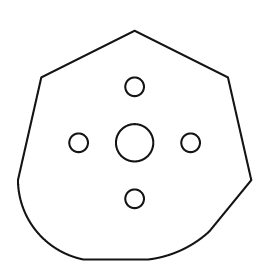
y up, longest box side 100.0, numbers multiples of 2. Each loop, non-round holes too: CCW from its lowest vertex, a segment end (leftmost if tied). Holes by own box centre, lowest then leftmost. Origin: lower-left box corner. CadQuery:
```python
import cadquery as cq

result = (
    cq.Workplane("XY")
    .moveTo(28.0, 0.0)
    .lineTo(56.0, 0.0)
    .threePointArc((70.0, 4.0), (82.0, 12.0))
    .lineTo(100.0, 34.0)
    .lineTo(90.0, 78.0)
    .lineTo(50.0, 98.0)
    .lineTo(10.0, 78.0)
    .lineTo(0.0, 34.0)
    .threePointArc((8.0, 12.0), (28.0, 0.0))
    .close()
    .moveTo(50.0, 26.0)
    .circle(4.0)
    .moveTo(26.0, 50.0)
    .circle(4.0)
    .moveTo(50.0, 50.0)
    .circle(8.0)
    .moveTo(74.0, 50.0)
    .circle(4.0)
    .moveTo(50.0, 74.0)
    .circle(4.0)
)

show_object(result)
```